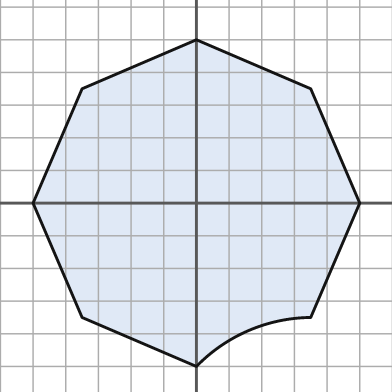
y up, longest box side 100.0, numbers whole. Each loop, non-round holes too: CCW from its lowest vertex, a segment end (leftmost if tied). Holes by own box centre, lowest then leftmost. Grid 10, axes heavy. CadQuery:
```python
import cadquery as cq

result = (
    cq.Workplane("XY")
    .moveTo(0.0, -50.0)
    .threePointArc((16.0, -39.0), (35.0, -35.0))
    .lineTo(50.0, 0.0)
    .lineTo(35.0, 35.0)
    .lineTo(0.0, 50.0)
    .lineTo(-35.0, 35.0)
    .lineTo(-50.0, 0.0)
    .lineTo(-35.0, -35.0)
    .close()
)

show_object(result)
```